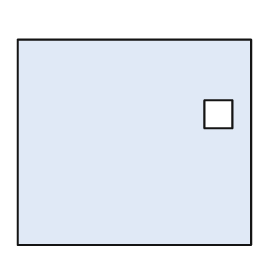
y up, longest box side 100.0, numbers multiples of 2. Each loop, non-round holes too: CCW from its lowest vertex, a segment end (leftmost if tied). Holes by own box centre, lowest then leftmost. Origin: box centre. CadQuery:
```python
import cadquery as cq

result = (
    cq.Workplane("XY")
    .moveTo(-50.0, -44.0)
    .lineTo(50.0, -44.0)
    .lineTo(50.0, 44.0)
    .lineTo(-50.0, 44.0)
    .close()
    .moveTo(30.0, 6.0)
    .lineTo(42.0, 6.0)
    .lineTo(42.0, 18.0)
    .lineTo(30.0, 18.0)
    .close()
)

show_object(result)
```